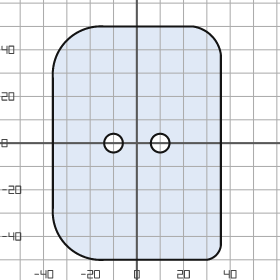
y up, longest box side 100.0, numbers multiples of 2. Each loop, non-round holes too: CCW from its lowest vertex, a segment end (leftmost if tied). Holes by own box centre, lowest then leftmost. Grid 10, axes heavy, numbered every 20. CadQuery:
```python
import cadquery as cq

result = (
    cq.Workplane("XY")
    .moveTo(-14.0, -50.0)
    .lineTo(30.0, -50.0)
    .threePointArc((34.0, -48.0), (36.0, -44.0))
    .lineTo(36.0, 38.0)
    .threePointArc((32.0, 46.0), (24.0, 50.0))
    .lineTo(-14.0, 50.0)
    .threePointArc((-30.0, 44.0), (-36.0, 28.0))
    .lineTo(-36.0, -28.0)
    .threePointArc((-30.0, -44.0), (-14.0, -50.0))
    .close()
    .moveTo(-10.0, 0.0)
    .circle(4.0)
    .moveTo(10.0, 0.0)
    .circle(4.0)
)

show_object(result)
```